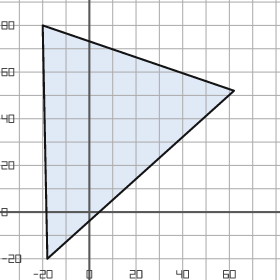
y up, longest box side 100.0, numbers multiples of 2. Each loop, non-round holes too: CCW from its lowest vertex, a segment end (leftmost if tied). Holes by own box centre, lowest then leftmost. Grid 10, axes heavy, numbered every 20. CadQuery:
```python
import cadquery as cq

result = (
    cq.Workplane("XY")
    .moveTo(-18.0, -20.0)
    .lineTo(62.0, 52.0)
    .lineTo(-20.0, 80.0)
    .close()
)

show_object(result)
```